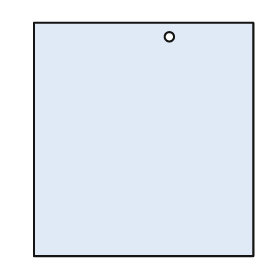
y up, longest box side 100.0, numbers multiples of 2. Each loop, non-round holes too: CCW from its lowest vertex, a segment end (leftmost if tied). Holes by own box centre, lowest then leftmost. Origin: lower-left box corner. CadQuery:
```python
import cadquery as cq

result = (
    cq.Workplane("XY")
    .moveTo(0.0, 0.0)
    .lineTo(94.0, 0.0)
    .lineTo(94.0, 100.0)
    .lineTo(0.0, 100.0)
    .close()
    .moveTo(58.0, 94.0)
    .circle(2.0)
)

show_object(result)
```